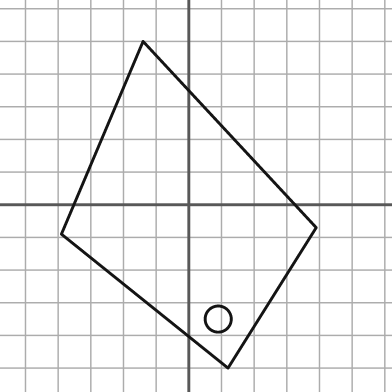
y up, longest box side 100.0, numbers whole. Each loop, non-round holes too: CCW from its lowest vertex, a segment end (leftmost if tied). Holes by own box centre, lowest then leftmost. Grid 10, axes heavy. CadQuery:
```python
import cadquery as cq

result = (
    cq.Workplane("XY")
    .moveTo(12.0, -50.0)
    .lineTo(39.0, -7.0)
    .lineTo(-14.0, 50.0)
    .lineTo(-39.0, -9.0)
    .close()
    .moveTo(9.0, -35.0)
    .circle(4.0)
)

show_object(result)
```